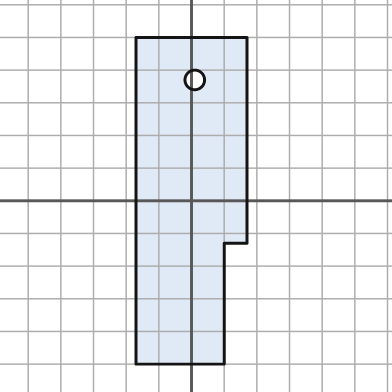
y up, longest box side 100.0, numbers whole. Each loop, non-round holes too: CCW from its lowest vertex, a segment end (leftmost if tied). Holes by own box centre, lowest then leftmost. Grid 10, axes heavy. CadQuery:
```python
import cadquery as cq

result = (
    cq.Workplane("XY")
    .moveTo(-17.0, -50.0)
    .lineTo(10.0, -50.0)
    .lineTo(10.0, -13.0)
    .lineTo(17.0, -13.0)
    .lineTo(17.0, 50.0)
    .lineTo(-17.0, 50.0)
    .close()
    .moveTo(1.0, 37.0)
    .circle(3.0)
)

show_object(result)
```